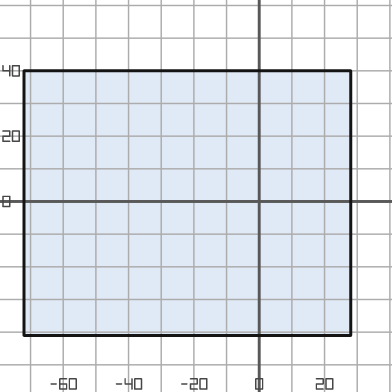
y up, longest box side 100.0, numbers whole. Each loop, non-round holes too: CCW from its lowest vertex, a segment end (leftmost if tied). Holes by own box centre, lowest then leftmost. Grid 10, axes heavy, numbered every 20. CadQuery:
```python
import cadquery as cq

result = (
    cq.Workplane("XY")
    .moveTo(-72.0, -41.0)
    .lineTo(28.0, -41.0)
    .lineTo(28.0, 40.0)
    .lineTo(-72.0, 40.0)
    .close()
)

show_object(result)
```